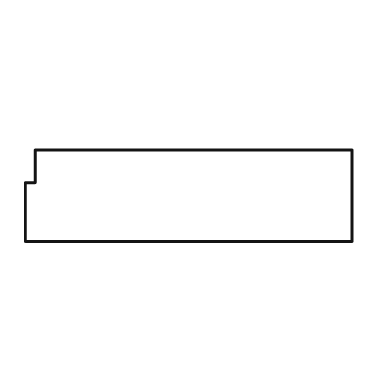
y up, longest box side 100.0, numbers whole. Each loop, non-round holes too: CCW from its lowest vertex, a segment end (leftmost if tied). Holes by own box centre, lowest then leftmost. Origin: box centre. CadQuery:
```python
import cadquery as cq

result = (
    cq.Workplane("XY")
    .moveTo(-50.0, -14.0)
    .lineTo(50.0, -14.0)
    .lineTo(50.0, 14.0)
    .lineTo(-47.0, 14.0)
    .lineTo(-47.0, 4.0)
    .lineTo(-50.0, 4.0)
    .close()
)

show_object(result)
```